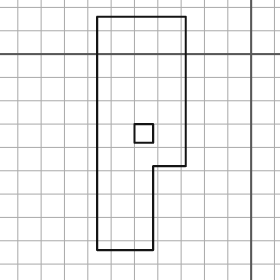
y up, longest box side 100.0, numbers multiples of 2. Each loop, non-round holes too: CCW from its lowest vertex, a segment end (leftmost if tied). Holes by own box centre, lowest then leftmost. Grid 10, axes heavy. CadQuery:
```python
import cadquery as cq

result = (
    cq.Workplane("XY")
    .moveTo(-66.0, -84.0)
    .lineTo(-42.0, -84.0)
    .lineTo(-42.0, -48.0)
    .lineTo(-28.0, -48.0)
    .lineTo(-28.0, 16.0)
    .lineTo(-66.0, 16.0)
    .close()
    .moveTo(-50.0, -38.0)
    .lineTo(-42.0, -38.0)
    .lineTo(-42.0, -30.0)
    .lineTo(-50.0, -30.0)
    .close()
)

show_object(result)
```